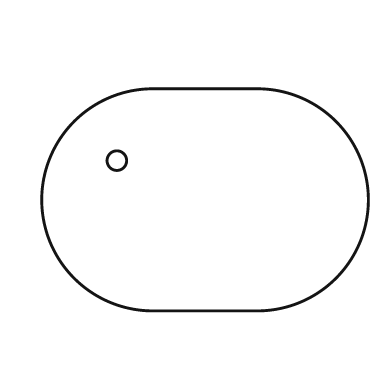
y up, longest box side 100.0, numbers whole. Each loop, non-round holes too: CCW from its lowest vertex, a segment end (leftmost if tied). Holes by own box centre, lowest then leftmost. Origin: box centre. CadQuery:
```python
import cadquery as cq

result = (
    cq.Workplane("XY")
    .moveTo(-16.0, -34.0)
    .lineTo(16.0, -34.0)
    .threePointArc((50.0, 0.0), (16.0, 34.0))
    .lineTo(-16.0, 34.0)
    .threePointArc((-50.0, 0.0), (-16.0, -34.0))
    .close()
    .moveTo(-27.0, 12.0)
    .circle(3.0)
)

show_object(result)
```